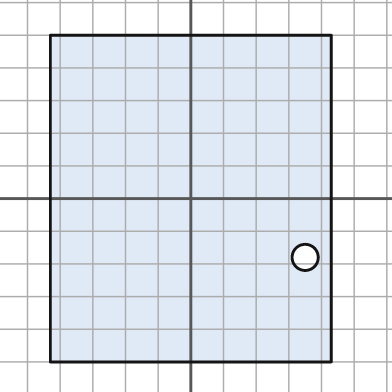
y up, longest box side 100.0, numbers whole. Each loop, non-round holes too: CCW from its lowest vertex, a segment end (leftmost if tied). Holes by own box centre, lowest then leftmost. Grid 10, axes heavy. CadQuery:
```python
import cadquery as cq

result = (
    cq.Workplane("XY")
    .moveTo(-43.0, -50.0)
    .lineTo(43.0, -50.0)
    .lineTo(43.0, 50.0)
    .lineTo(-43.0, 50.0)
    .close()
    .moveTo(35.0, -18.0)
    .circle(4.0)
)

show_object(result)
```